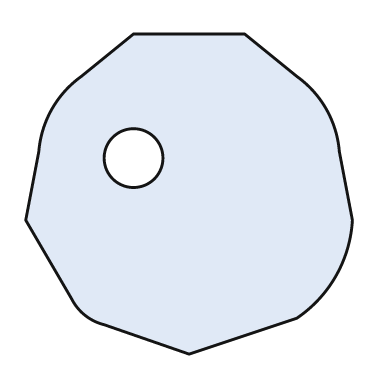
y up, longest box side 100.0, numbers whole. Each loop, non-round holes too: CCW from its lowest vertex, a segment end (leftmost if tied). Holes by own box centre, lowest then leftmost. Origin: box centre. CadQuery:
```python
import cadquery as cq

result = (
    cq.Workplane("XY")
    .moveTo(0.0, -49.0)
    .lineTo(33.0, -38.0)
    .threePointArc((45.0, -25.0), (50.0, -8.0))
    .lineTo(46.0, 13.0)
    .threePointArc((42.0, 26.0), (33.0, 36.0))
    .lineTo(17.0, 49.0)
    .lineTo(-17.0, 49.0)
    .lineTo(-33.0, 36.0)
    .threePointArc((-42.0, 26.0), (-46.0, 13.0))
    .lineTo(-50.0, -8.0)
    .lineTo(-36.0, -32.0)
    .threePointArc((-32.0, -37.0), (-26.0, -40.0))
    .close()
    .moveTo(-17.0, 11.0)
    .circle(9.0)
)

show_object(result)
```